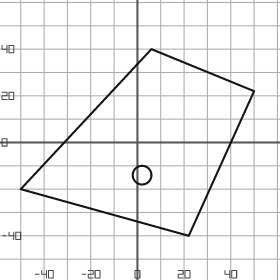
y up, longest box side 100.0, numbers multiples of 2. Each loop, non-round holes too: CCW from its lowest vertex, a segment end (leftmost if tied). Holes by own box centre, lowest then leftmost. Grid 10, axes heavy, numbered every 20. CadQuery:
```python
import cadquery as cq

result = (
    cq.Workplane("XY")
    .moveTo(22.0, -40.0)
    .lineTo(50.0, 22.0)
    .lineTo(6.0, 40.0)
    .lineTo(-50.0, -20.0)
    .close()
    .moveTo(2.0, -14.0)
    .circle(4.0)
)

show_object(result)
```